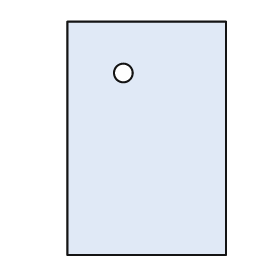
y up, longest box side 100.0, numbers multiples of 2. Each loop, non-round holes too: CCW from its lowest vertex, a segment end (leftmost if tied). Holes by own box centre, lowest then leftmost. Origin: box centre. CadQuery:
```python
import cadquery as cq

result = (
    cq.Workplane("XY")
    .moveTo(-34.0, -50.0)
    .lineTo(34.0, -50.0)
    .lineTo(34.0, 50.0)
    .lineTo(-34.0, 50.0)
    .close()
    .moveTo(-10.0, 28.0)
    .circle(4.0)
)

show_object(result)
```